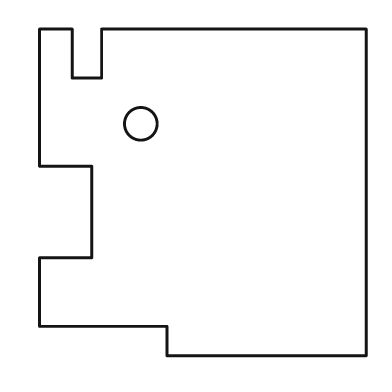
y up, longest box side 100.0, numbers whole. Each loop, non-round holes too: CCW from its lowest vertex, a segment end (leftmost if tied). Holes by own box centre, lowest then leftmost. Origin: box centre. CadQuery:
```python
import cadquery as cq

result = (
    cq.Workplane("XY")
    .moveTo(-11.0, -50.0)
    .lineTo(50.0, -50.0)
    .lineTo(50.0, 50.0)
    .lineTo(-31.0, 50.0)
    .lineTo(-31.0, 35.0)
    .lineTo(-40.0, 35.0)
    .lineTo(-40.0, 50.0)
    .lineTo(-50.0, 50.0)
    .lineTo(-50.0, 8.0)
    .lineTo(-34.0, 8.0)
    .lineTo(-34.0, -20.0)
    .lineTo(-50.0, -20.0)
    .lineTo(-50.0, -41.0)
    .lineTo(-11.0, -41.0)
    .close()
    .moveTo(-19.0, 21.0)
    .circle(5.0)
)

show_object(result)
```